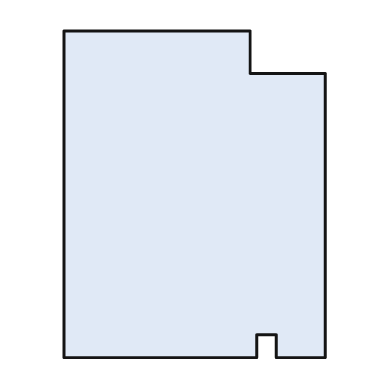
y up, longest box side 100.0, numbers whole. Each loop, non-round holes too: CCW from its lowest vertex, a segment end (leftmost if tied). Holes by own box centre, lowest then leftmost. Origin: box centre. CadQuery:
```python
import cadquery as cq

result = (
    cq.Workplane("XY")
    .moveTo(-40.0, -50.0)
    .lineTo(19.0, -50.0)
    .lineTo(19.0, -43.0)
    .lineTo(25.0, -43.0)
    .lineTo(25.0, -50.0)
    .lineTo(40.0, -50.0)
    .lineTo(40.0, 37.0)
    .lineTo(17.0, 37.0)
    .lineTo(17.0, 50.0)
    .lineTo(-40.0, 50.0)
    .close()
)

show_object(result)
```